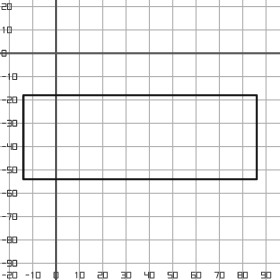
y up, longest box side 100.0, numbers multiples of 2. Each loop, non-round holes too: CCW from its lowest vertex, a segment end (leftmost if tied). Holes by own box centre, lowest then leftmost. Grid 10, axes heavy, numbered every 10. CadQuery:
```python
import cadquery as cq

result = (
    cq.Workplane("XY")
    .moveTo(-14.0, -54.0)
    .lineTo(86.0, -54.0)
    .lineTo(86.0, -18.0)
    .lineTo(-14.0, -18.0)
    .close()
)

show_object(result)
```